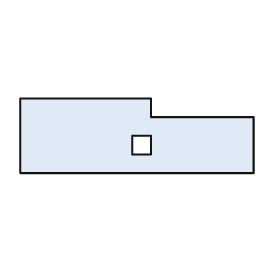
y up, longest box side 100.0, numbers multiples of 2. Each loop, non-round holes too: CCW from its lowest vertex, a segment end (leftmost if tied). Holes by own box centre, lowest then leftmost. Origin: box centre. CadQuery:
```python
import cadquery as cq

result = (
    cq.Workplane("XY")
    .moveTo(-50.0, -16.0)
    .lineTo(50.0, -16.0)
    .lineTo(50.0, 8.0)
    .lineTo(6.0, 8.0)
    .lineTo(6.0, 16.0)
    .lineTo(-50.0, 16.0)
    .close()
    .moveTo(-2.0, -8.0)
    .lineTo(6.0, -8.0)
    .lineTo(6.0, 0.0)
    .lineTo(-2.0, 0.0)
    .close()
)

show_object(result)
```